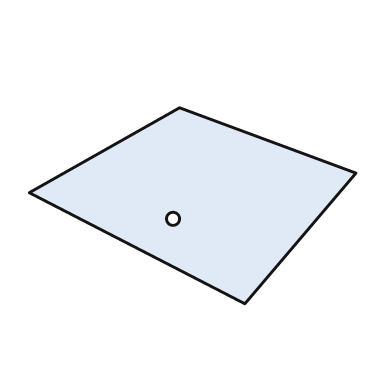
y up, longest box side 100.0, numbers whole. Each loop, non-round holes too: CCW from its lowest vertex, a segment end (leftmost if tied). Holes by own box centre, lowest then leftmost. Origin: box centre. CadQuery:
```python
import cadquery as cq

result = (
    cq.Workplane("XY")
    .moveTo(16.0, -30.0)
    .lineTo(50.0, 10.0)
    .lineTo(-4.0, 30.0)
    .lineTo(-50.0, 4.0)
    .close()
    .moveTo(-6.0, -4.0)
    .circle(2.0)
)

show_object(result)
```